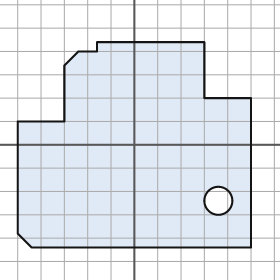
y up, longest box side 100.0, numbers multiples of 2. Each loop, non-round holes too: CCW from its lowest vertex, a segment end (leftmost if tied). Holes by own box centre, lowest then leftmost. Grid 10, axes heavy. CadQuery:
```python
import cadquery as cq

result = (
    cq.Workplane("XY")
    .moveTo(-44.0, -44.0)
    .lineTo(50.0, -44.0)
    .lineTo(50.0, 20.0)
    .lineTo(30.0, 20.0)
    .lineTo(30.0, 44.0)
    .lineTo(-16.0, 44.0)
    .lineTo(-16.0, 40.0)
    .lineTo(-24.0, 40.0)
    .lineTo(-30.0, 34.0)
    .lineTo(-30.0, 10.0)
    .lineTo(-50.0, 10.0)
    .lineTo(-50.0, -38.0)
    .close()
    .moveTo(36.0, -24.0)
    .circle(6.0)
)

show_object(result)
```